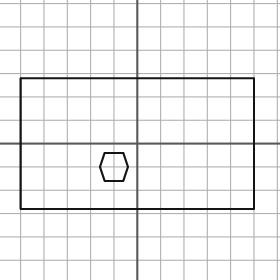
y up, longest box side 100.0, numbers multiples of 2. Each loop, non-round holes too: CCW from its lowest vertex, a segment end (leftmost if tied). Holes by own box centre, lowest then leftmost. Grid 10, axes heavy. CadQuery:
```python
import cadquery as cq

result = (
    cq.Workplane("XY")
    .moveTo(-50.0, -28.0)
    .lineTo(50.0, -28.0)
    .lineTo(50.0, 28.0)
    .lineTo(-50.0, 28.0)
    .close()
    .moveTo(-14.0, -16.0)
    .lineTo(-6.0, -16.0)
    .lineTo(-4.0, -10.0)
    .lineTo(-6.0, -4.0)
    .lineTo(-14.0, -4.0)
    .lineTo(-16.0, -10.0)
    .close()
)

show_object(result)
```